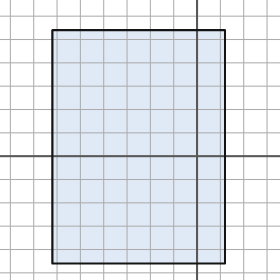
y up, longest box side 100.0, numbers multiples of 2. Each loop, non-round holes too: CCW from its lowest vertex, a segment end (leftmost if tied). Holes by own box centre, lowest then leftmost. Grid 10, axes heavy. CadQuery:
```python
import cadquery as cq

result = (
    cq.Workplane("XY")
    .moveTo(-62.0, -46.0)
    .lineTo(12.0, -46.0)
    .lineTo(12.0, 54.0)
    .lineTo(-62.0, 54.0)
    .close()
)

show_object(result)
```